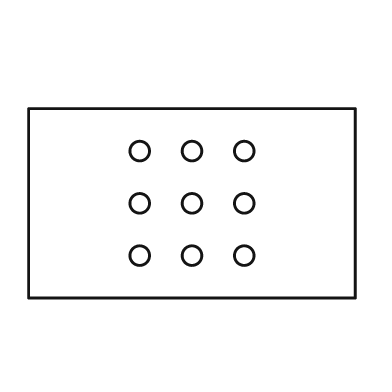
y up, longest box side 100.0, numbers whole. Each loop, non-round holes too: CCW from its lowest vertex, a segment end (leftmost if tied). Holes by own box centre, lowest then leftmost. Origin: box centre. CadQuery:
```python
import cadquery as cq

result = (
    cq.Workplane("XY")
    .moveTo(-50.0, -29.0)
    .lineTo(50.0, -29.0)
    .lineTo(50.0, 29.0)
    .lineTo(-50.0, 29.0)
    .close()
    .moveTo(-16.0, -16.0)
    .circle(3.0)
    .moveTo(0.0, -16.0)
    .circle(3.0)
    .moveTo(16.0, -16.0)
    .circle(3.0)
    .moveTo(-16.0, 0.0)
    .circle(3.0)
    .moveTo(0.0, 0.0)
    .circle(3.0)
    .moveTo(16.0, 0.0)
    .circle(3.0)
    .moveTo(-16.0, 16.0)
    .circle(3.0)
    .moveTo(0.0, 16.0)
    .circle(3.0)
    .moveTo(16.0, 16.0)
    .circle(3.0)
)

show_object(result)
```